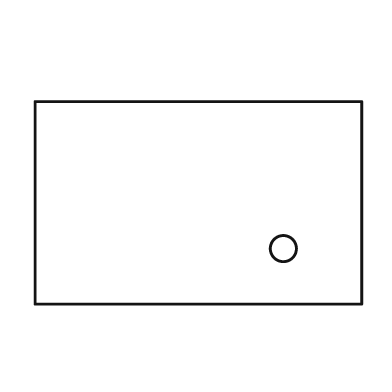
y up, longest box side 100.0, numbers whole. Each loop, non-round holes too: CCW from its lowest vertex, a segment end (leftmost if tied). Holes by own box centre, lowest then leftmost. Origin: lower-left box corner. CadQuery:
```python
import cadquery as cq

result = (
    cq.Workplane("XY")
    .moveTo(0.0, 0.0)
    .lineTo(100.0, 0.0)
    .lineTo(100.0, 62.0)
    .lineTo(0.0, 62.0)
    .close()
    .moveTo(76.0, 17.0)
    .circle(4.0)
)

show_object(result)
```